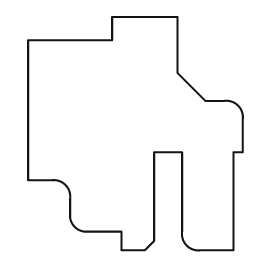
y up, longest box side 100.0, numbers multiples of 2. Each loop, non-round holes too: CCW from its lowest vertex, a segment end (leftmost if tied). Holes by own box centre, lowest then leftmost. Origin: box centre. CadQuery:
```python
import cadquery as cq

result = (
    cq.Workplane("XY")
    .moveTo(-6.0, -50.0)
    .lineTo(4.0, -50.0)
    .lineTo(8.0, -46.0)
    .lineTo(8.0, -8.0)
    .lineTo(20.0, -8.0)
    .lineTo(20.0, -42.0)
    .threePointArc((22.0, -48.0), (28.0, -50.0))
    .lineTo(42.0, -50.0)
    .lineTo(42.0, -8.0)
    .lineTo(46.0, -8.0)
    .lineTo(46.0, 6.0)
    .threePointArc((44.0, 12.0), (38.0, 14.0))
    .lineTo(30.0, 14.0)
    .lineTo(18.0, 26.0)
    .lineTo(18.0, 50.0)
    .lineTo(-10.0, 50.0)
    .lineTo(-10.0, 40.0)
    .lineTo(-46.0, 40.0)
    .lineTo(-46.0, -20.0)
    .lineTo(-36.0, -20.0)
    .threePointArc((-30.0, -22.0), (-28.0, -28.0))
    .lineTo(-28.0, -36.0)
    .threePointArc((-26.0, -40.0), (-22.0, -42.0))
    .lineTo(-6.0, -42.0)
    .close()
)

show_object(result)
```